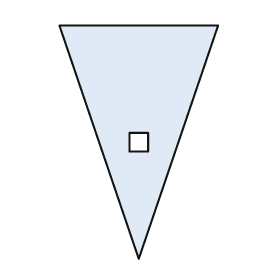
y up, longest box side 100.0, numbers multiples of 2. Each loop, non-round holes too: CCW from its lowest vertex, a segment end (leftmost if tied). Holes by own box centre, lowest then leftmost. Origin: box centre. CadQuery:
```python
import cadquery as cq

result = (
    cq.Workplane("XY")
    .moveTo(0.0, -50.0)
    .lineTo(34.0, 50.0)
    .lineTo(-34.0, 50.0)
    .close()
    .moveTo(-4.0, -4.0)
    .lineTo(4.0, -4.0)
    .lineTo(4.0, 4.0)
    .lineTo(-4.0, 4.0)
    .close()
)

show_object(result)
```